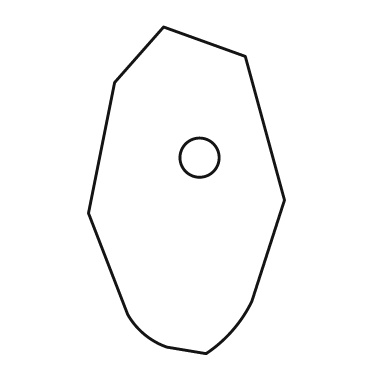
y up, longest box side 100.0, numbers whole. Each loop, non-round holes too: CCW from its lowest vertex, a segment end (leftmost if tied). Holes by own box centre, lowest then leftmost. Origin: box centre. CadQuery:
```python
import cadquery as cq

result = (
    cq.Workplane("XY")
    .moveTo(6.0, -50.0)
    .threePointArc((14.0, -43.0), (20.0, -34.0))
    .lineTo(30.0, -3.0)
    .lineTo(18.0, 41.0)
    .lineTo(-7.0, 50.0)
    .lineTo(-22.0, 33.0)
    .lineTo(-30.0, -7.0)
    .lineTo(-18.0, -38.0)
    .threePointArc((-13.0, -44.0), (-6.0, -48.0))
    .close()
    .moveTo(4.0, 10.0)
    .circle(6.0)
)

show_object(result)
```